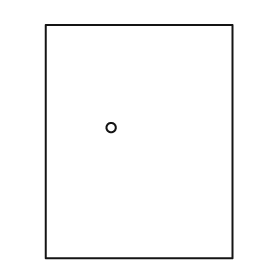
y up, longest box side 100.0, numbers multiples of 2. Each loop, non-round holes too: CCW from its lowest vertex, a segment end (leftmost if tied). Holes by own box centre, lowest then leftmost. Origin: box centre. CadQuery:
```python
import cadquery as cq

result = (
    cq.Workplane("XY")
    .moveTo(-40.0, -50.0)
    .lineTo(40.0, -50.0)
    .lineTo(40.0, 50.0)
    .lineTo(-40.0, 50.0)
    .close()
    .moveTo(-12.0, 6.0)
    .circle(2.0)
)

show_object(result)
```